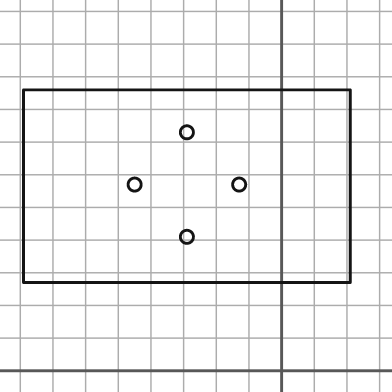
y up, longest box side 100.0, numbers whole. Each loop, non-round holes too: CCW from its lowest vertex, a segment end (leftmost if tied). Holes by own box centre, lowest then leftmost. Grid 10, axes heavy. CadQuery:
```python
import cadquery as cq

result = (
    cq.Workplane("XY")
    .moveTo(-79.0, 27.0)
    .lineTo(21.0, 27.0)
    .lineTo(21.0, 86.0)
    .lineTo(-79.0, 86.0)
    .close()
    .moveTo(-29.0, 41.0)
    .circle(2.0)
    .moveTo(-45.0, 57.0)
    .circle(2.0)
    .moveTo(-13.0, 57.0)
    .circle(2.0)
    .moveTo(-29.0, 73.0)
    .circle(2.0)
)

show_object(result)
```